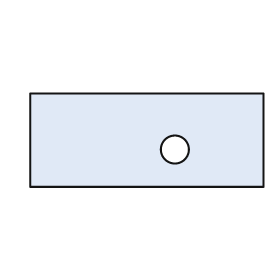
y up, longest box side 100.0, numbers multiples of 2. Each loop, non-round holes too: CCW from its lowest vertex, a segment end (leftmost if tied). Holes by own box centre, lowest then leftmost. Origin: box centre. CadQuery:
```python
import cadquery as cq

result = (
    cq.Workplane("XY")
    .moveTo(-50.0, -20.0)
    .lineTo(50.0, -20.0)
    .lineTo(50.0, 20.0)
    .lineTo(-50.0, 20.0)
    .close()
    .moveTo(12.0, -4.0)
    .circle(6.0)
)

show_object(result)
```